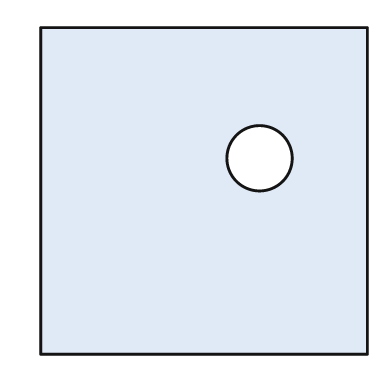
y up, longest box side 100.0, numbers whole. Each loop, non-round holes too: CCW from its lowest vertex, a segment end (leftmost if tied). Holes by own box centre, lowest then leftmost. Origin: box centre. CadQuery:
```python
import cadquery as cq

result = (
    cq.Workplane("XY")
    .moveTo(-50.0, -50.0)
    .lineTo(50.0, -50.0)
    .lineTo(50.0, 50.0)
    .lineTo(-50.0, 50.0)
    .close()
    .moveTo(17.0, 10.0)
    .circle(10.0)
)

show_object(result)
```